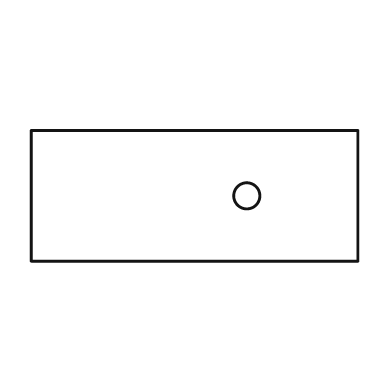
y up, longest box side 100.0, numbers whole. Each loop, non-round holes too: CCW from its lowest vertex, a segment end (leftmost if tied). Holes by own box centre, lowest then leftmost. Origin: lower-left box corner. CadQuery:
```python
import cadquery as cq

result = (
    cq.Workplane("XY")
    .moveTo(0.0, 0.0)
    .lineTo(100.0, 0.0)
    .lineTo(100.0, 40.0)
    .lineTo(0.0, 40.0)
    .close()
    .moveTo(66.0, 20.0)
    .circle(4.0)
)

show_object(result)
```